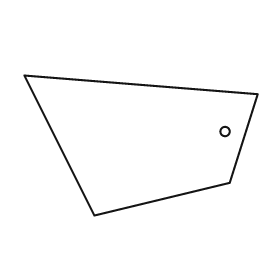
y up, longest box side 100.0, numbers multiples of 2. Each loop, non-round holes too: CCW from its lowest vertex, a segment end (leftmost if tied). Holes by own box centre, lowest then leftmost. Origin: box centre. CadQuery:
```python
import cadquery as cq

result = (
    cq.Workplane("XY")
    .moveTo(-20.0, -30.0)
    .lineTo(38.0, -16.0)
    .lineTo(50.0, 22.0)
    .lineTo(-50.0, 30.0)
    .close()
    .moveTo(36.0, 6.0)
    .circle(2.0)
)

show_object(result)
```